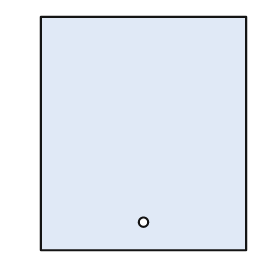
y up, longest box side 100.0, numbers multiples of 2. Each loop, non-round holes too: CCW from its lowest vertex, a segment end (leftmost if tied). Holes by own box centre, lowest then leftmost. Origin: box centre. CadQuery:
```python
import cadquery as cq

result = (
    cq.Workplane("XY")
    .moveTo(-44.0, -50.0)
    .lineTo(44.0, -50.0)
    .lineTo(44.0, 50.0)
    .lineTo(-44.0, 50.0)
    .close()
    .moveTo(0.0, -38.0)
    .circle(2.0)
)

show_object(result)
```